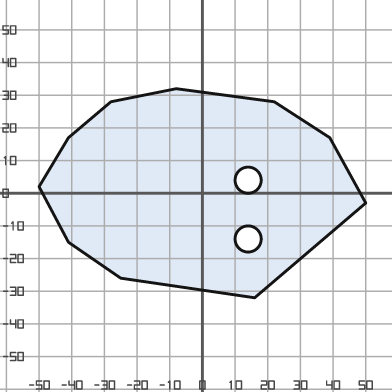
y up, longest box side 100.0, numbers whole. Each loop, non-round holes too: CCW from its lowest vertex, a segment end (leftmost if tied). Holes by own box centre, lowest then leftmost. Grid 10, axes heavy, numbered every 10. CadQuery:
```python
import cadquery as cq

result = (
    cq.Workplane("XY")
    .moveTo(16.0, -32.0)
    .lineTo(50.0, -3.0)
    .lineTo(39.0, 17.0)
    .lineTo(22.0, 28.0)
    .lineTo(-8.0, 32.0)
    .lineTo(-28.0, 28.0)
    .lineTo(-41.0, 17.0)
    .lineTo(-50.0, 2.0)
    .lineTo(-41.0, -15.0)
    .lineTo(-25.0, -26.0)
    .close()
    .moveTo(14.0, -14.0)
    .circle(4.0)
    .moveTo(14.0, 4.0)
    .circle(4.0)
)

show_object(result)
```